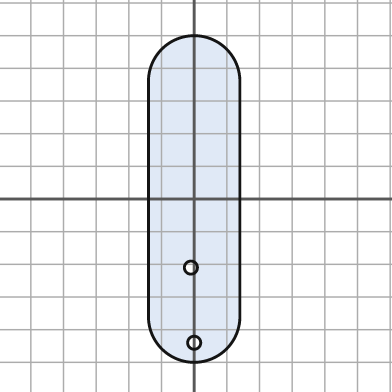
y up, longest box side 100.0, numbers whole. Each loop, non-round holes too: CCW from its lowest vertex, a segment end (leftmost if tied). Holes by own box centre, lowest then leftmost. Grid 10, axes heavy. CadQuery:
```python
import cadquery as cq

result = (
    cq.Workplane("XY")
    .moveTo(-14.0, -36.0)
    .threePointArc((0.0, -50.0), (14.0, -36.0))
    .lineTo(14.0, 36.0)
    .threePointArc((0.0, 50.0), (-14.0, 36.0))
    .close()
    .moveTo(0.0, -44.0)
    .circle(2.0)
    .moveTo(-1.0, -21.0)
    .circle(2.0)
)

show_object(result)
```